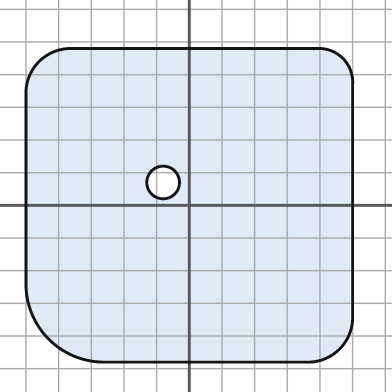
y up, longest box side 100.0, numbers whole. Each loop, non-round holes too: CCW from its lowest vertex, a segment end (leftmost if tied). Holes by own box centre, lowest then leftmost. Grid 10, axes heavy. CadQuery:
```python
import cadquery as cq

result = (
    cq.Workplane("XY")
    .moveTo(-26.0, -48.0)
    .lineTo(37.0, -48.0)
    .threePointArc((46.0, -44.0), (50.0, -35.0))
    .lineTo(50.0, 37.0)
    .threePointArc((47.0, 45.0), (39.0, 48.0))
    .lineTo(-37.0, 48.0)
    .threePointArc((-46.0, 44.0), (-50.0, 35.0))
    .lineTo(-50.0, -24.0)
    .threePointArc((-43.0, -41.0), (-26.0, -48.0))
    .close()
    .moveTo(-8.0, 7.0)
    .circle(5.0)
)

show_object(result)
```